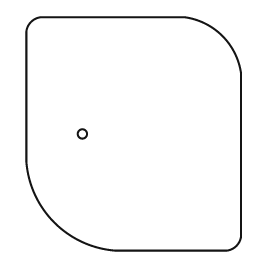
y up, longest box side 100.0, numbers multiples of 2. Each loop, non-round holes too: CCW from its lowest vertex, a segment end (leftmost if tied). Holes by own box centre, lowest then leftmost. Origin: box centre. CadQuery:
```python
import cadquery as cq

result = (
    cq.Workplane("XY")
    .moveTo(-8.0, -50.0)
    .lineTo(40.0, -50.0)
    .threePointArc((44.0, -48.0), (46.0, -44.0))
    .lineTo(46.0, 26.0)
    .threePointArc((38.0, 42.0), (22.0, 50.0))
    .lineTo(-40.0, 50.0)
    .threePointArc((-44.0, 48.0), (-46.0, 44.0))
    .lineTo(-46.0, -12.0)
    .threePointArc((-34.0, -38.0), (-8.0, -50.0))
    .close()
    .moveTo(-22.0, 0.0)
    .circle(2.0)
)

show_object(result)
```